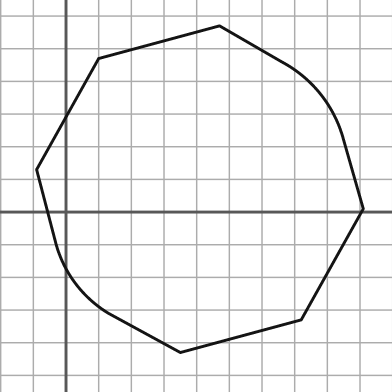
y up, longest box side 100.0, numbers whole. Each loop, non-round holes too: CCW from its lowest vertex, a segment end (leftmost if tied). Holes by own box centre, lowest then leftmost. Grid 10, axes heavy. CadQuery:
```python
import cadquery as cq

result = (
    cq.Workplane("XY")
    .moveTo(35.0, -43.0)
    .lineTo(72.0, -33.0)
    .lineTo(91.0, 1.0)
    .lineTo(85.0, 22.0)
    .threePointArc((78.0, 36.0), (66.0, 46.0))
    .lineTo(47.0, 57.0)
    .lineTo(10.0, 47.0)
    .lineTo(-9.0, 13.0)
    .lineTo(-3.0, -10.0)
    .threePointArc((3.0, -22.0), (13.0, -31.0))
    .close()
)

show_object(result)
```